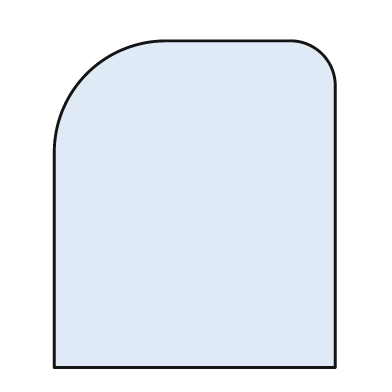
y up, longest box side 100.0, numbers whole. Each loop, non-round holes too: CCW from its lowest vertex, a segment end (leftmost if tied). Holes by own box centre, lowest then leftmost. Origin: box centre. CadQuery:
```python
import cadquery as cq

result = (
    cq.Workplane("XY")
    .moveTo(-43.0, -50.0)
    .lineTo(43.0, -50.0)
    .lineTo(43.0, 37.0)
    .threePointArc((39.0, 46.0), (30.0, 50.0))
    .lineTo(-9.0, 50.0)
    .threePointArc((-33.0, 40.0), (-43.0, 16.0))
    .close()
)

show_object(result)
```